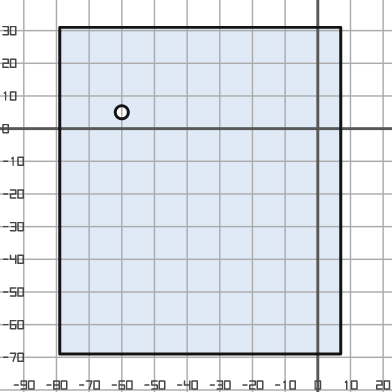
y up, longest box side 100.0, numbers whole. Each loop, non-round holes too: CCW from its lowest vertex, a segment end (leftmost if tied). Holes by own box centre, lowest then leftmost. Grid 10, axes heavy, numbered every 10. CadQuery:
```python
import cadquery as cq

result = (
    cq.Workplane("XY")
    .moveTo(-79.0, -69.0)
    .lineTo(7.0, -69.0)
    .lineTo(7.0, 31.0)
    .lineTo(-79.0, 31.0)
    .close()
    .moveTo(-60.0, 5.0)
    .circle(2.0)
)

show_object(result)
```